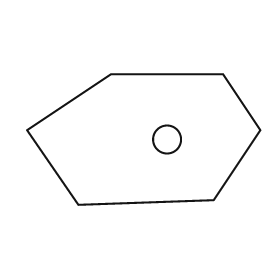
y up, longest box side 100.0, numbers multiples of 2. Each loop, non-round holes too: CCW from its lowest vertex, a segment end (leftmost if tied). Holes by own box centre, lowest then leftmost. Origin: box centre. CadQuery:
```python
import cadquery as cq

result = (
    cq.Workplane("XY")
    .moveTo(-28.0, -28.0)
    .lineTo(30.0, -26.0)
    .lineTo(50.0, 4.0)
    .lineTo(34.0, 28.0)
    .lineTo(-14.0, 28.0)
    .lineTo(-50.0, 4.0)
    .close()
    .moveTo(10.0, 0.0)
    .circle(6.0)
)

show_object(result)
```